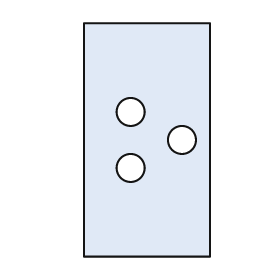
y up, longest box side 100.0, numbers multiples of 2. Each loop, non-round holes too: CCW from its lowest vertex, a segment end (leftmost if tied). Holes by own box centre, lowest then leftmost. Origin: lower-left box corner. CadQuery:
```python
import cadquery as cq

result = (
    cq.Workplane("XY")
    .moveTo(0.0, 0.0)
    .lineTo(54.0, 0.0)
    .lineTo(54.0, 100.0)
    .lineTo(0.0, 100.0)
    .close()
    .moveTo(20.0, 38.0)
    .circle(6.0)
    .moveTo(42.0, 50.0)
    .circle(6.0)
    .moveTo(20.0, 62.0)
    .circle(6.0)
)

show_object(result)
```